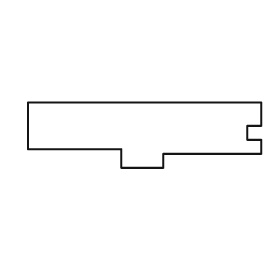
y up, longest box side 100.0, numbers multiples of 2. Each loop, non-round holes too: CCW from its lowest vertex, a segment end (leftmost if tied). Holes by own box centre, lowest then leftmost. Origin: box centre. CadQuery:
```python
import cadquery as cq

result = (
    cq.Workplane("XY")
    .moveTo(-10.0, -14.0)
    .lineTo(8.0, -14.0)
    .lineTo(8.0, -8.0)
    .lineTo(50.0, -8.0)
    .lineTo(50.0, -2.0)
    .lineTo(44.0, -2.0)
    .lineTo(44.0, 4.0)
    .lineTo(50.0, 4.0)
    .lineTo(50.0, 14.0)
    .lineTo(-50.0, 14.0)
    .lineTo(-50.0, -6.0)
    .lineTo(-10.0, -6.0)
    .close()
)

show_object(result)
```